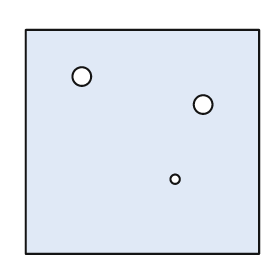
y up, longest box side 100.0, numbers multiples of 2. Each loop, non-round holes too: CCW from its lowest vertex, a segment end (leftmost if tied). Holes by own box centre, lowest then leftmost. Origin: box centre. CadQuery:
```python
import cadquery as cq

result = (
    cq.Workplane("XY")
    .moveTo(-50.0, -48.0)
    .lineTo(50.0, -48.0)
    .lineTo(50.0, 48.0)
    .lineTo(-50.0, 48.0)
    .close()
    .moveTo(14.0, -16.0)
    .circle(2.0)
    .moveTo(26.0, 16.0)
    .circle(4.0)
    .moveTo(-26.0, 28.0)
    .circle(4.0)
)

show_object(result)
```